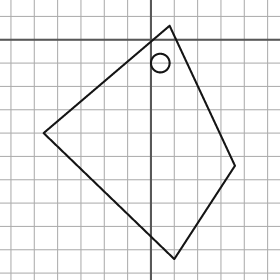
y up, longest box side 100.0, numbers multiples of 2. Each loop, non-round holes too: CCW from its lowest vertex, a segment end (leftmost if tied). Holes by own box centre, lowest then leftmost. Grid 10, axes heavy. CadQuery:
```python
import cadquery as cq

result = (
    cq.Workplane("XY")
    .moveTo(10.0, -94.0)
    .lineTo(36.0, -54.0)
    .lineTo(8.0, 6.0)
    .lineTo(-46.0, -40.0)
    .close()
    .moveTo(4.0, -10.0)
    .circle(4.0)
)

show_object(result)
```